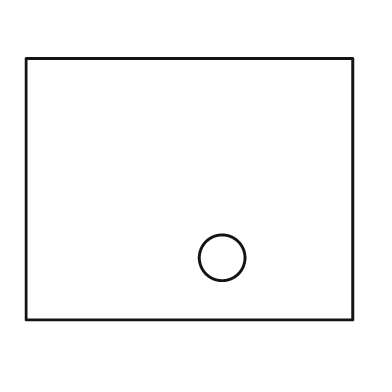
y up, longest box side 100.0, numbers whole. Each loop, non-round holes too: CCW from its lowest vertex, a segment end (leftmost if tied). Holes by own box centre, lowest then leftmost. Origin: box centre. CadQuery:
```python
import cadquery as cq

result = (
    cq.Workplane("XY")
    .moveTo(-50.0, -40.0)
    .lineTo(50.0, -40.0)
    .lineTo(50.0, 40.0)
    .lineTo(-50.0, 40.0)
    .close()
    .moveTo(10.0, -21.0)
    .circle(7.0)
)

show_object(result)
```